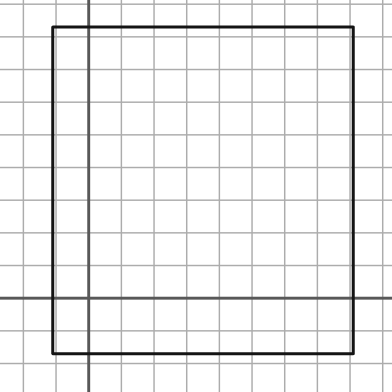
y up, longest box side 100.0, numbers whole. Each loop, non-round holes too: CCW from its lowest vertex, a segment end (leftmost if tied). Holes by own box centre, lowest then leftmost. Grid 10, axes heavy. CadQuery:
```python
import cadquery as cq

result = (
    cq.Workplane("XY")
    .moveTo(-11.0, -17.0)
    .lineTo(81.0, -17.0)
    .lineTo(81.0, 83.0)
    .lineTo(-11.0, 83.0)
    .close()
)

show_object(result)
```